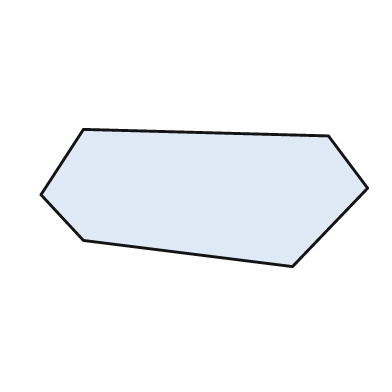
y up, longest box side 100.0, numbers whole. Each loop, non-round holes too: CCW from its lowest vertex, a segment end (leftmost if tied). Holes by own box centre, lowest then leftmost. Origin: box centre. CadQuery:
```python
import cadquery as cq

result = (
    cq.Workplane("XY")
    .moveTo(27.0, -21.0)
    .lineTo(50.0, 3.0)
    .lineTo(38.0, 19.0)
    .lineTo(-37.0, 21.0)
    .lineTo(-50.0, 1.0)
    .lineTo(-37.0, -13.0)
    .close()
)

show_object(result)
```